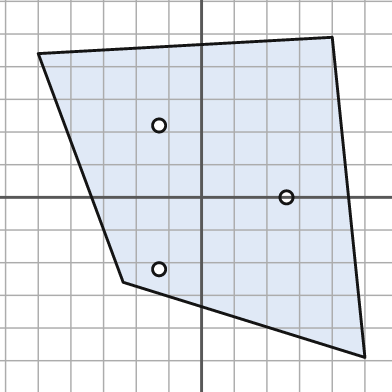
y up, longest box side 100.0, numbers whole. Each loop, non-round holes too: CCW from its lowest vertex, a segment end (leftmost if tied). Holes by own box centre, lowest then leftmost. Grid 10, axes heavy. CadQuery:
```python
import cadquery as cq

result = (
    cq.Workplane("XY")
    .moveTo(50.0, -49.0)
    .lineTo(40.0, 49.0)
    .lineTo(-50.0, 44.0)
    .lineTo(-24.0, -26.0)
    .close()
    .moveTo(-13.0, -22.0)
    .circle(2.0)
    .moveTo(26.0, 0.0)
    .circle(2.0)
    .moveTo(-13.0, 22.0)
    .circle(2.0)
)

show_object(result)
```